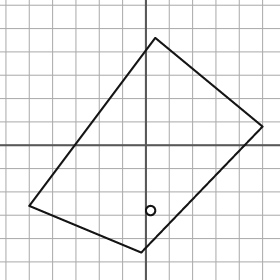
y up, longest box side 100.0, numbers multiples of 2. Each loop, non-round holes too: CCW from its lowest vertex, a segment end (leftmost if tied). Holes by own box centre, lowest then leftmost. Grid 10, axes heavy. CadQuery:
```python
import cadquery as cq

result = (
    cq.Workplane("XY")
    .moveTo(-2.0, -46.0)
    .lineTo(50.0, 8.0)
    .lineTo(4.0, 46.0)
    .lineTo(-50.0, -26.0)
    .close()
    .moveTo(2.0, -28.0)
    .circle(2.0)
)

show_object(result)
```